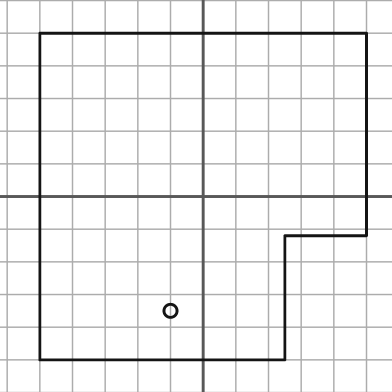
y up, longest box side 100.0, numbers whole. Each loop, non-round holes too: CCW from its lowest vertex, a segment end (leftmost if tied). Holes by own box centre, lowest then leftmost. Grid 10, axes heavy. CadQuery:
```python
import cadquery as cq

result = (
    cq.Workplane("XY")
    .moveTo(-50.0, -50.0)
    .lineTo(25.0, -50.0)
    .lineTo(25.0, -12.0)
    .lineTo(50.0, -12.0)
    .lineTo(50.0, 50.0)
    .lineTo(-50.0, 50.0)
    .close()
    .moveTo(-10.0, -35.0)
    .circle(2.0)
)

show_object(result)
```